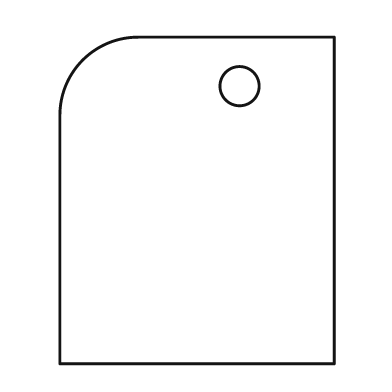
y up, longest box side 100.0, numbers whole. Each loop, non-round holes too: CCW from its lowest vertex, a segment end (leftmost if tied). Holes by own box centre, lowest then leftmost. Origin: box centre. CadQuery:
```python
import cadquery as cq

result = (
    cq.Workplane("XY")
    .moveTo(-42.0, -50.0)
    .lineTo(42.0, -50.0)
    .lineTo(42.0, 50.0)
    .lineTo(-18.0, 50.0)
    .threePointArc((-35.0, 43.0), (-42.0, 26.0))
    .close()
    .moveTo(13.0, 35.0)
    .circle(6.0)
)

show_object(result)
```